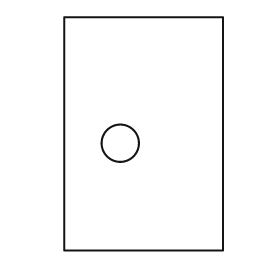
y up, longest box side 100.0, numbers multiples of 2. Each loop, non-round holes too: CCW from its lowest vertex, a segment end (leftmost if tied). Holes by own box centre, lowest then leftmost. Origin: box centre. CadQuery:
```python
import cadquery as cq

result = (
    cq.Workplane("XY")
    .moveTo(-34.0, -50.0)
    .lineTo(34.0, -50.0)
    .lineTo(34.0, 50.0)
    .lineTo(-34.0, 50.0)
    .close()
    .moveTo(-10.0, -4.0)
    .circle(8.0)
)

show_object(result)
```